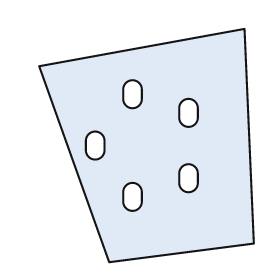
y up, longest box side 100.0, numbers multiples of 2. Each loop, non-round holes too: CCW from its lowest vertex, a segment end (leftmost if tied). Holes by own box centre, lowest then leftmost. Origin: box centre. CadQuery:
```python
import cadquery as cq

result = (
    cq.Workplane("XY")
    .moveTo(-16.0, -50.0)
    .lineTo(46.0, -42.0)
    .lineTo(42.0, 50.0)
    .lineTo(-46.0, 34.0)
    .close()
    .moveTo(-10.0, -24.0)
    .threePointArc((-6.0, -28.0), (-2.0, -24.0))
    .lineTo(-2.0, -20.0)
    .threePointArc((-6.0, -16.0), (-10.0, -20.0))
    .close()
    .moveTo(14.0, -16.0)
    .threePointArc((18.0, -20.0), (22.0, -16.0))
    .lineTo(22.0, -12.0)
    .threePointArc((18.0, -8.0), (14.0, -12.0))
    .close()
    .moveTo(-26.0, -2.0)
    .threePointArc((-22.0, -6.0), (-18.0, -2.0))
    .lineTo(-18.0, 2.0)
    .threePointArc((-22.0, 6.0), (-26.0, 2.0))
    .close()
    .moveTo(14.0, 12.0)
    .threePointArc((18.0, 8.0), (22.0, 12.0))
    .lineTo(22.0, 16.0)
    .threePointArc((18.0, 20.0), (14.0, 16.0))
    .close()
    .moveTo(-10.0, 20.0)
    .threePointArc((-6.0, 16.0), (-2.0, 20.0))
    .lineTo(-2.0, 24.0)
    .threePointArc((-6.0, 28.0), (-10.0, 24.0))
    .close()
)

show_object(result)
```